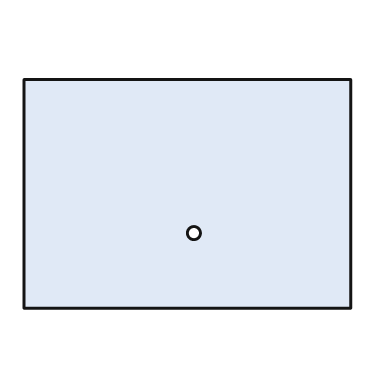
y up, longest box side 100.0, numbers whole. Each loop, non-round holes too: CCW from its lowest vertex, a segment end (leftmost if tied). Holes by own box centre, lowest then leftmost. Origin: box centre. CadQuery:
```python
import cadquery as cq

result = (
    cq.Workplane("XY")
    .moveTo(-50.0, -35.0)
    .lineTo(50.0, -35.0)
    .lineTo(50.0, 35.0)
    .lineTo(-50.0, 35.0)
    .close()
    .moveTo(2.0, -12.0)
    .circle(2.0)
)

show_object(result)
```